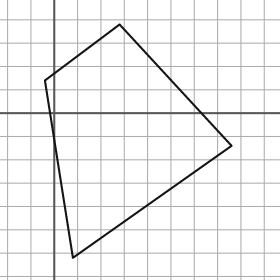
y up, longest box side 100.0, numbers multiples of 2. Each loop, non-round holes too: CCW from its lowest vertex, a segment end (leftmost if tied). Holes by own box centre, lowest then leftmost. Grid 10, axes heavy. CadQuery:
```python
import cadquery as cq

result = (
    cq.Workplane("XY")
    .moveTo(8.0, -62.0)
    .lineTo(76.0, -14.0)
    .lineTo(28.0, 38.0)
    .lineTo(-4.0, 14.0)
    .close()
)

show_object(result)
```